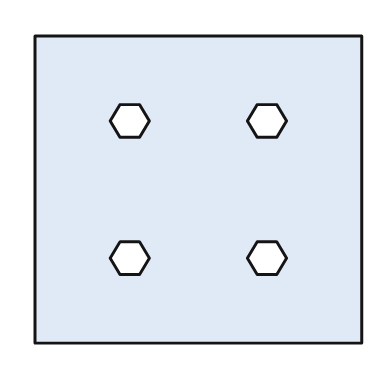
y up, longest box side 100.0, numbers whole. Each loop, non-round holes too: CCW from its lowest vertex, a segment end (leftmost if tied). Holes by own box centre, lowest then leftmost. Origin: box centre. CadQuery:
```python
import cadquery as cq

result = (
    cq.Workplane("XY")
    .moveTo(-50.0, -47.0)
    .lineTo(50.0, -47.0)
    .lineTo(50.0, 47.0)
    .lineTo(-50.0, 47.0)
    .close()
    .moveTo(-24.0, -26.0)
    .lineTo(-18.0, -26.0)
    .lineTo(-15.0, -21.0)
    .lineTo(-18.0, -16.0)
    .lineTo(-24.0, -16.0)
    .lineTo(-27.0, -21.0)
    .close()
    .moveTo(18.0, -26.0)
    .lineTo(24.0, -26.0)
    .lineTo(27.0, -21.0)
    .lineTo(24.0, -16.0)
    .lineTo(18.0, -16.0)
    .lineTo(15.0, -21.0)
    .close()
    .moveTo(-24.0, 16.0)
    .lineTo(-18.0, 16.0)
    .lineTo(-15.0, 21.0)
    .lineTo(-18.0, 26.0)
    .lineTo(-24.0, 26.0)
    .lineTo(-27.0, 21.0)
    .close()
    .moveTo(18.0, 16.0)
    .lineTo(24.0, 16.0)
    .lineTo(27.0, 21.0)
    .lineTo(24.0, 26.0)
    .lineTo(18.0, 26.0)
    .lineTo(15.0, 21.0)
    .close()
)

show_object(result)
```